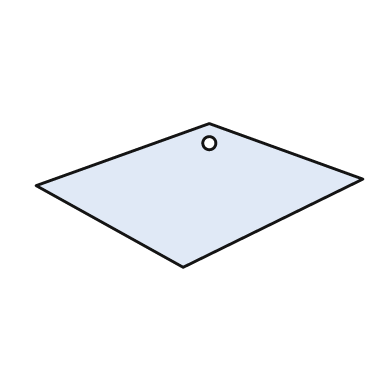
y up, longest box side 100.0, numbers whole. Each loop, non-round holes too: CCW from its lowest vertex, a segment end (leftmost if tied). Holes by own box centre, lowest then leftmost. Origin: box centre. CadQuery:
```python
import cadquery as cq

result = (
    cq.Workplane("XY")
    .moveTo(-5.0, -22.0)
    .lineTo(50.0, 5.0)
    .lineTo(3.0, 22.0)
    .lineTo(-50.0, 3.0)
    .close()
    .moveTo(3.0, 16.0)
    .circle(2.0)
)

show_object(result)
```